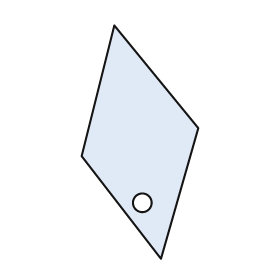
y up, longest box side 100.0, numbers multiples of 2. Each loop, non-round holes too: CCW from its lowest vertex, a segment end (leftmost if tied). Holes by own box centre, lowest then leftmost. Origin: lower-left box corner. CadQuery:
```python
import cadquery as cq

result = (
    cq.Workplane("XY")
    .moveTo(34.0, 0.0)
    .lineTo(50.0, 56.0)
    .lineTo(14.0, 100.0)
    .lineTo(0.0, 44.0)
    .close()
    .moveTo(26.0, 24.0)
    .circle(4.0)
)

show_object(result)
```